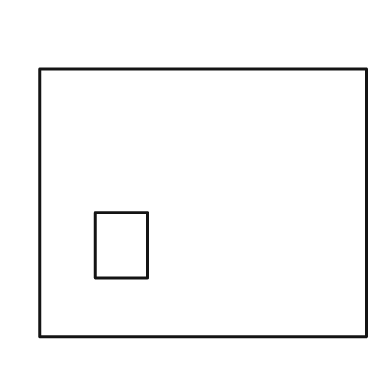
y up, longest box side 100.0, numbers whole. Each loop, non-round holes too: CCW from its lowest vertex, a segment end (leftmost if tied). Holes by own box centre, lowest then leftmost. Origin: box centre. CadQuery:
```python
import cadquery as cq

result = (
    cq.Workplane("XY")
    .moveTo(-50.0, -41.0)
    .lineTo(50.0, -41.0)
    .lineTo(50.0, 41.0)
    .lineTo(-50.0, 41.0)
    .close()
    .moveTo(-33.0, -23.0)
    .lineTo(-17.0, -23.0)
    .lineTo(-17.0, -3.0)
    .lineTo(-33.0, -3.0)
    .close()
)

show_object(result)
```